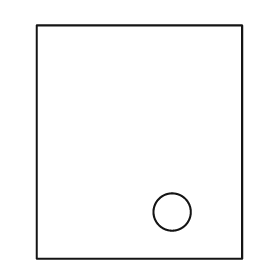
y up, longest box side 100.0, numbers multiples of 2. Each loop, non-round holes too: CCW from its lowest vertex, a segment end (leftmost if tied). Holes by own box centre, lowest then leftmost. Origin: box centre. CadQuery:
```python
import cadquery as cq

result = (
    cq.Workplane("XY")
    .moveTo(-44.0, -50.0)
    .lineTo(44.0, -50.0)
    .lineTo(44.0, 50.0)
    .lineTo(-44.0, 50.0)
    .close()
    .moveTo(14.0, -30.0)
    .circle(8.0)
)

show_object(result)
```